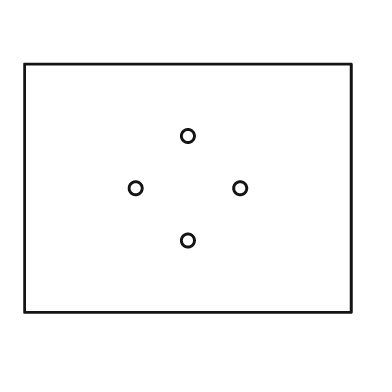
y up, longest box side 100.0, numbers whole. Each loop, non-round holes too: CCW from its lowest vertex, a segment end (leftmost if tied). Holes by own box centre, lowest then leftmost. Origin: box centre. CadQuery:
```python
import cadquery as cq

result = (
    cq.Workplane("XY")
    .moveTo(-50.0, -38.0)
    .lineTo(50.0, -38.0)
    .lineTo(50.0, 38.0)
    .lineTo(-50.0, 38.0)
    .close()
    .moveTo(0.0, -16.0)
    .circle(2.0)
    .moveTo(-16.0, 0.0)
    .circle(2.0)
    .moveTo(16.0, 0.0)
    .circle(2.0)
    .moveTo(0.0, 16.0)
    .circle(2.0)
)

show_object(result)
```